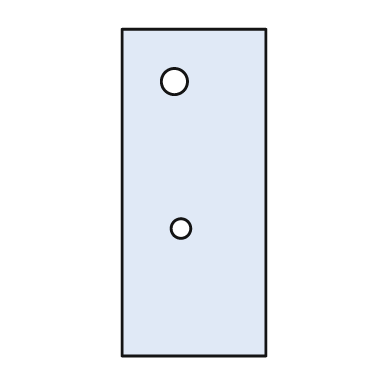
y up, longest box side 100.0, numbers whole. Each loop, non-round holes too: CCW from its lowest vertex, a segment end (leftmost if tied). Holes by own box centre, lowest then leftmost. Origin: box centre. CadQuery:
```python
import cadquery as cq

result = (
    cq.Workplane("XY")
    .moveTo(-22.0, -50.0)
    .lineTo(22.0, -50.0)
    .lineTo(22.0, 50.0)
    .lineTo(-22.0, 50.0)
    .close()
    .moveTo(-4.0, -11.0)
    .circle(3.0)
    .moveTo(-6.0, 34.0)
    .circle(4.0)
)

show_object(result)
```